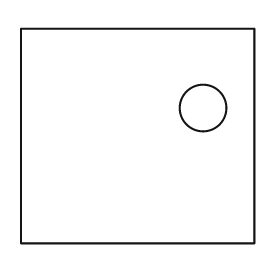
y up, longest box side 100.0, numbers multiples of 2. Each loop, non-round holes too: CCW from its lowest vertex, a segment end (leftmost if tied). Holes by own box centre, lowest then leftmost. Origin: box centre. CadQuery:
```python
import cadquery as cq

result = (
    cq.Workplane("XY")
    .moveTo(-50.0, -46.0)
    .lineTo(50.0, -46.0)
    .lineTo(50.0, 46.0)
    .lineTo(-50.0, 46.0)
    .close()
    .moveTo(28.0, 12.0)
    .circle(10.0)
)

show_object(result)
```